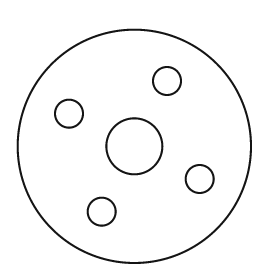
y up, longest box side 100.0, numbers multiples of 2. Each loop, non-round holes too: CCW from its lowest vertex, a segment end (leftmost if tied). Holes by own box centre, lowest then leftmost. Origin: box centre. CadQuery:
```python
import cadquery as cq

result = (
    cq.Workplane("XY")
    .moveTo(0.0, 0.0)
    .circle(50.0)
    .moveTo(-14.0, -28.0)
    .circle(6.0)
    .moveTo(28.0, -14.0)
    .circle(6.0)
    .moveTo(0.0, 0.0)
    .circle(12.0)
    .moveTo(-28.0, 14.0)
    .circle(6.0)
    .moveTo(14.0, 28.0)
    .circle(6.0)
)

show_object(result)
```